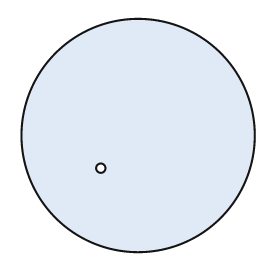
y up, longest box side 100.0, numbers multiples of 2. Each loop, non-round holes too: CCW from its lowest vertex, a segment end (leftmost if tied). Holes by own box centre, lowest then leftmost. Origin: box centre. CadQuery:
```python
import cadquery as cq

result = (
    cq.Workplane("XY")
    .moveTo(0.0, 0.0)
    .circle(50.0)
    .moveTo(-16.0, -14.0)
    .circle(2.0)
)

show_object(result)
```